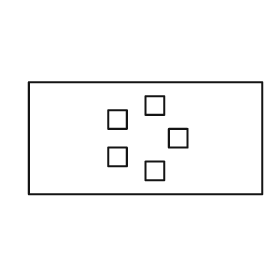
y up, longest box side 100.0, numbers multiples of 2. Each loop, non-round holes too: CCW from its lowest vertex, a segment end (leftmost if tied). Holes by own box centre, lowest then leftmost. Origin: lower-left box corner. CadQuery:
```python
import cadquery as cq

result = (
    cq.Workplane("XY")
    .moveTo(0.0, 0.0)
    .lineTo(100.0, 0.0)
    .lineTo(100.0, 48.0)
    .lineTo(0.0, 48.0)
    .close()
    .moveTo(50.0, 6.0)
    .lineTo(58.0, 6.0)
    .lineTo(58.0, 14.0)
    .lineTo(50.0, 14.0)
    .close()
    .moveTo(34.0, 12.0)
    .lineTo(42.0, 12.0)
    .lineTo(42.0, 20.0)
    .lineTo(34.0, 20.0)
    .close()
    .moveTo(60.0, 20.0)
    .lineTo(68.0, 20.0)
    .lineTo(68.0, 28.0)
    .lineTo(60.0, 28.0)
    .close()
    .moveTo(34.0, 28.0)
    .lineTo(42.0, 28.0)
    .lineTo(42.0, 36.0)
    .lineTo(34.0, 36.0)
    .close()
    .moveTo(50.0, 34.0)
    .lineTo(58.0, 34.0)
    .lineTo(58.0, 42.0)
    .lineTo(50.0, 42.0)
    .close()
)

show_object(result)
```